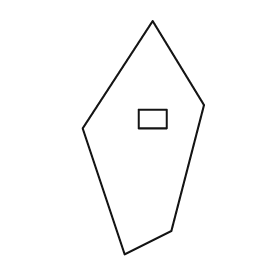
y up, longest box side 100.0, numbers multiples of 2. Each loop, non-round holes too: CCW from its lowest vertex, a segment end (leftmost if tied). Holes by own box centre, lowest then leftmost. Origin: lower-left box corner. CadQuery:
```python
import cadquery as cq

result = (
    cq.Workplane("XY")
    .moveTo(18.0, 0.0)
    .lineTo(38.0, 10.0)
    .lineTo(52.0, 64.0)
    .lineTo(30.0, 100.0)
    .lineTo(0.0, 54.0)
    .close()
    .moveTo(24.0, 54.0)
    .lineTo(36.0, 54.0)
    .lineTo(36.0, 62.0)
    .lineTo(24.0, 62.0)
    .close()
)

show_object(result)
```